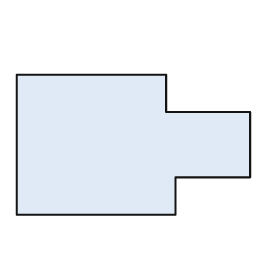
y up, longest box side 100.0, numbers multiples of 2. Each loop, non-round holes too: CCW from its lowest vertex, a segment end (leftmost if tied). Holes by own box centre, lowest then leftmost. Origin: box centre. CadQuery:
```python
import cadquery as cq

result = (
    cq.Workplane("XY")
    .moveTo(-50.0, -30.0)
    .lineTo(18.0, -30.0)
    .lineTo(18.0, -14.0)
    .lineTo(50.0, -14.0)
    .lineTo(50.0, 14.0)
    .lineTo(14.0, 14.0)
    .lineTo(14.0, 30.0)
    .lineTo(-50.0, 30.0)
    .close()
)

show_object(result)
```